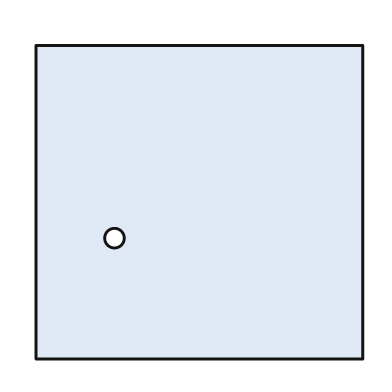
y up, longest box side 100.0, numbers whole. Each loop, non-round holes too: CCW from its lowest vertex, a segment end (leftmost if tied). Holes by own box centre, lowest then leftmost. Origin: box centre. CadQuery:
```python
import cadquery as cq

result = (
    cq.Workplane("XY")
    .moveTo(-50.0, -48.0)
    .lineTo(50.0, -48.0)
    .lineTo(50.0, 48.0)
    .lineTo(-50.0, 48.0)
    .close()
    .moveTo(-26.0, -11.0)
    .circle(3.0)
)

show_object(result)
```